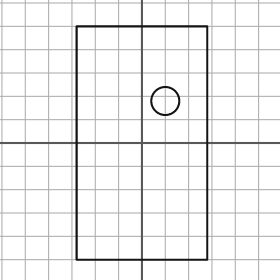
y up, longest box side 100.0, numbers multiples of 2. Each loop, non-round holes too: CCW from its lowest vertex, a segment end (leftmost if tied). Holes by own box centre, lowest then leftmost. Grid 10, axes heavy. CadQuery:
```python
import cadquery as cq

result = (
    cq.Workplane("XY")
    .moveTo(-28.0, -50.0)
    .lineTo(28.0, -50.0)
    .lineTo(28.0, 50.0)
    .lineTo(-28.0, 50.0)
    .close()
    .moveTo(10.0, 18.0)
    .circle(6.0)
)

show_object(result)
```